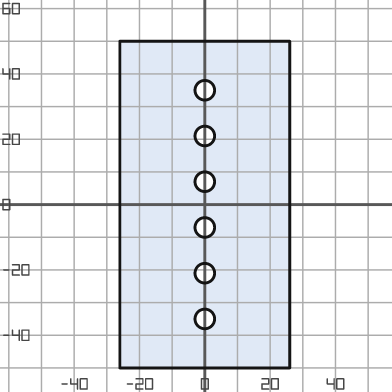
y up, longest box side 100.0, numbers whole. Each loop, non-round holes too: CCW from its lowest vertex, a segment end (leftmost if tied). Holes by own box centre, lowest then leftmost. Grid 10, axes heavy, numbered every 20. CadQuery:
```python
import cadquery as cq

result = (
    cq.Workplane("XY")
    .moveTo(-26.0, -50.0)
    .lineTo(26.0, -50.0)
    .lineTo(26.0, 50.0)
    .lineTo(-26.0, 50.0)
    .close()
    .moveTo(0.0, -35.0)
    .circle(3.0)
    .moveTo(0.0, -21.0)
    .circle(3.0)
    .moveTo(0.0, -7.0)
    .circle(3.0)
    .moveTo(0.0, 7.0)
    .circle(3.0)
    .moveTo(0.0, 21.0)
    .circle(3.0)
    .moveTo(0.0, 35.0)
    .circle(3.0)
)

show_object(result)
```